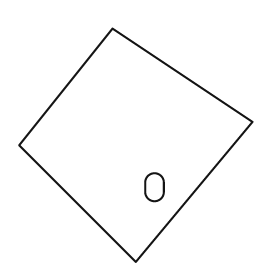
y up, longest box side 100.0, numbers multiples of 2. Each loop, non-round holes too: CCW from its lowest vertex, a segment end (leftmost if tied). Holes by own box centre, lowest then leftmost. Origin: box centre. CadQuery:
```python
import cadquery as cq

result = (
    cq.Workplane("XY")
    .moveTo(0.0, -50.0)
    .lineTo(50.0, 10.0)
    .lineTo(-10.0, 50.0)
    .lineTo(-50.0, 0.0)
    .close()
    .moveTo(4.0, -20.0)
    .threePointArc((8.0, -24.0), (12.0, -20.0))
    .lineTo(12.0, -16.0)
    .threePointArc((8.0, -12.0), (4.0, -16.0))
    .close()
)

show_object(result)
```